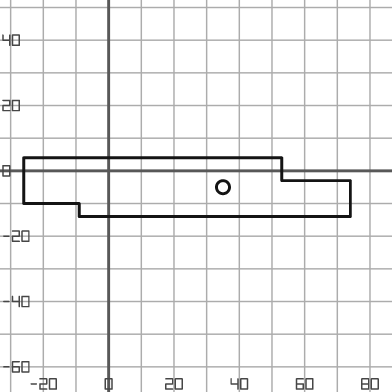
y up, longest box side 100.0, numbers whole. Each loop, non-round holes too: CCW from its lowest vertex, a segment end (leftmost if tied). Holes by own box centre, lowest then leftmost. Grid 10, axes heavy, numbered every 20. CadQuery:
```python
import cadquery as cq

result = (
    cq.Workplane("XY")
    .moveTo(-9.0, -14.0)
    .lineTo(74.0, -14.0)
    .lineTo(74.0, -3.0)
    .lineTo(53.0, -3.0)
    .lineTo(53.0, 4.0)
    .lineTo(-26.0, 4.0)
    .lineTo(-26.0, -10.0)
    .lineTo(-9.0, -10.0)
    .close()
    .moveTo(35.0, -5.0)
    .circle(2.0)
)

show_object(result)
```